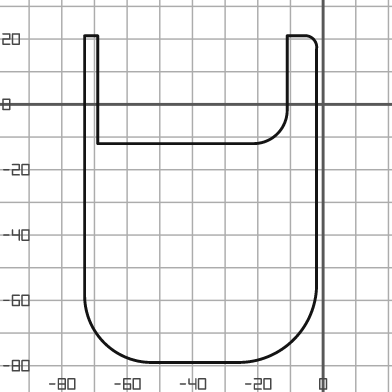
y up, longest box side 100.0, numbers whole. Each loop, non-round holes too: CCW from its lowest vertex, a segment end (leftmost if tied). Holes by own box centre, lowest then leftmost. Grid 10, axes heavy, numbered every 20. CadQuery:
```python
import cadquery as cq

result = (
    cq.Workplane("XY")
    .moveTo(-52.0, -79.0)
    .lineTo(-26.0, -79.0)
    .threePointArc((-9.0, -72.0), (-2.0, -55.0))
    .lineTo(-2.0, 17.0)
    .threePointArc((-3.0, 20.0), (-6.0, 21.0))
    .lineTo(-11.0, 21.0)
    .lineTo(-11.0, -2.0)
    .threePointArc((-14.0, -9.0), (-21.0, -12.0))
    .lineTo(-69.0, -12.0)
    .lineTo(-69.0, 21.0)
    .lineTo(-73.0, 21.0)
    .lineTo(-73.0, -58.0)
    .threePointArc((-67.0, -73.0), (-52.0, -79.0))
    .close()
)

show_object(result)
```